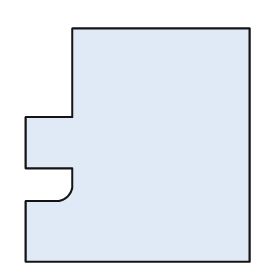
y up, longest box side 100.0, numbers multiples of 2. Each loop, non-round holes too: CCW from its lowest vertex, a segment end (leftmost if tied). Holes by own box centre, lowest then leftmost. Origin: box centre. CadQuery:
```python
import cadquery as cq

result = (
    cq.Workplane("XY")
    .moveTo(-48.0, -50.0)
    .lineTo(48.0, -50.0)
    .lineTo(48.0, 50.0)
    .lineTo(-28.0, 50.0)
    .lineTo(-28.0, 12.0)
    .lineTo(-48.0, 12.0)
    .lineTo(-48.0, -10.0)
    .lineTo(-28.0, -10.0)
    .lineTo(-28.0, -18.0)
    .threePointArc((-30.0, -22.0), (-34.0, -24.0))
    .lineTo(-48.0, -24.0)
    .close()
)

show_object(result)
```